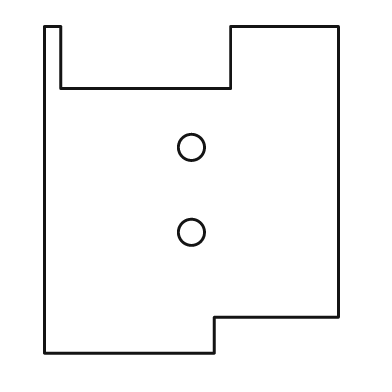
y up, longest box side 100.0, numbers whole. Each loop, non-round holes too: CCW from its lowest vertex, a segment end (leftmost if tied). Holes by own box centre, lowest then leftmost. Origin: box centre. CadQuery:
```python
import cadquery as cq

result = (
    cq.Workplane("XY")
    .moveTo(-45.0, -50.0)
    .lineTo(7.0, -50.0)
    .lineTo(7.0, -39.0)
    .lineTo(45.0, -39.0)
    .lineTo(45.0, 50.0)
    .lineTo(12.0, 50.0)
    .lineTo(12.0, 31.0)
    .lineTo(-40.0, 31.0)
    .lineTo(-40.0, 50.0)
    .lineTo(-45.0, 50.0)
    .close()
    .moveTo(0.0, -13.0)
    .circle(4.0)
    .moveTo(0.0, 13.0)
    .circle(4.0)
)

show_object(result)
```